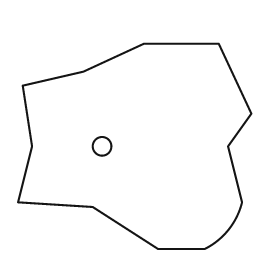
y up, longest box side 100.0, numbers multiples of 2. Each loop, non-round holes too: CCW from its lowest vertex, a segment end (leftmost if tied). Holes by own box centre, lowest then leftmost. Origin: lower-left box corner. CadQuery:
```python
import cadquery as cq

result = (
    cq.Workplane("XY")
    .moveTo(60.0, 0.0)
    .lineTo(80.0, 0.0)
    .threePointArc((90.0, 8.0), (96.0, 20.0))
    .lineTo(90.0, 44.0)
    .lineTo(100.0, 58.0)
    .lineTo(86.0, 88.0)
    .lineTo(54.0, 88.0)
    .lineTo(28.0, 76.0)
    .lineTo(2.0, 70.0)
    .lineTo(6.0, 44.0)
    .lineTo(0.0, 20.0)
    .lineTo(32.0, 18.0)
    .close()
    .moveTo(36.0, 44.0)
    .circle(4.0)
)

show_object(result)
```